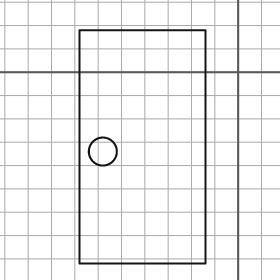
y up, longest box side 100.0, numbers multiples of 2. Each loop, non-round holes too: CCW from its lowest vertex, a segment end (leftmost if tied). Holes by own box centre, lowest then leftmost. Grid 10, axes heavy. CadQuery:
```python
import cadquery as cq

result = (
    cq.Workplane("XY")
    .moveTo(-68.0, -82.0)
    .lineTo(-14.0, -82.0)
    .lineTo(-14.0, 18.0)
    .lineTo(-68.0, 18.0)
    .close()
    .moveTo(-58.0, -34.0)
    .circle(6.0)
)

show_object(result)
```